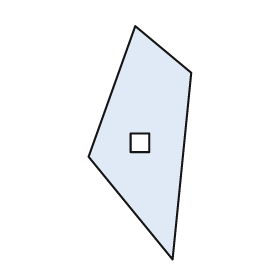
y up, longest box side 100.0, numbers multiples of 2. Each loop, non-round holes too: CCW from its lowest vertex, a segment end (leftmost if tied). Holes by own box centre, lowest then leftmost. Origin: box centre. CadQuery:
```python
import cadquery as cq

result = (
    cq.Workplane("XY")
    .moveTo(14.0, -50.0)
    .lineTo(22.0, 30.0)
    .lineTo(-2.0, 50.0)
    .lineTo(-22.0, -6.0)
    .close()
    .moveTo(-4.0, -4.0)
    .lineTo(4.0, -4.0)
    .lineTo(4.0, 4.0)
    .lineTo(-4.0, 4.0)
    .close()
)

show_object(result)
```